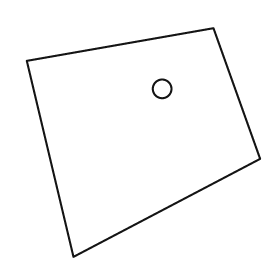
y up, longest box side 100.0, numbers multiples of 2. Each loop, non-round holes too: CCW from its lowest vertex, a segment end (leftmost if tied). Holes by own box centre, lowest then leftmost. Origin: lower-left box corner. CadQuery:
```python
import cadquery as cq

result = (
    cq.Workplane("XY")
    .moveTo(20.0, 0.0)
    .lineTo(100.0, 42.0)
    .lineTo(80.0, 98.0)
    .lineTo(0.0, 84.0)
    .close()
    .moveTo(58.0, 72.0)
    .circle(4.0)
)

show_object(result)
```